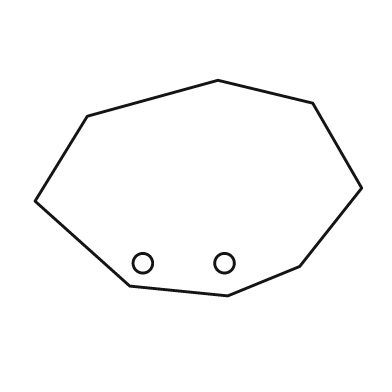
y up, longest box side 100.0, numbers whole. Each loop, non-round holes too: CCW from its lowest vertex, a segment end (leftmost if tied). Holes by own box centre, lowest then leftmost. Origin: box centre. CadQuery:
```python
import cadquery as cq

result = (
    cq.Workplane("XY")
    .moveTo(9.0, -33.0)
    .lineTo(31.0, -24.0)
    .lineTo(50.0, 0.0)
    .lineTo(35.0, 26.0)
    .lineTo(6.0, 33.0)
    .lineTo(-34.0, 22.0)
    .lineTo(-50.0, -4.0)
    .lineTo(-21.0, -30.0)
    .close()
    .moveTo(-17.0, -23.0)
    .circle(3.0)
    .moveTo(8.0, -23.0)
    .circle(3.0)
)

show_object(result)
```